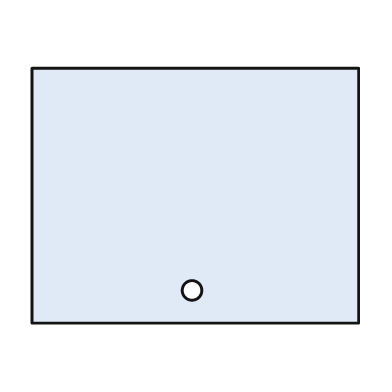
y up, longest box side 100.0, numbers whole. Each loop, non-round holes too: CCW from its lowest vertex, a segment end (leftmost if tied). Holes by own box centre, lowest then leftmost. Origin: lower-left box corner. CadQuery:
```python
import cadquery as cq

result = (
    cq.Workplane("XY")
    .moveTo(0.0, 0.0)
    .lineTo(100.0, 0.0)
    .lineTo(100.0, 78.0)
    .lineTo(0.0, 78.0)
    .close()
    .moveTo(49.0, 10.0)
    .circle(3.0)
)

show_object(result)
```